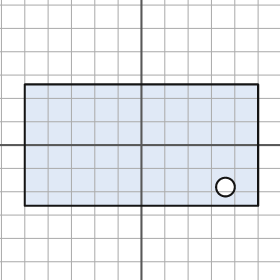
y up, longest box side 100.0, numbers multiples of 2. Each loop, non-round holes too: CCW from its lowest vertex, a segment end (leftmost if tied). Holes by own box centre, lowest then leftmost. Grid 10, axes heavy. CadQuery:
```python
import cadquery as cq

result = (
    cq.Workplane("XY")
    .moveTo(-50.0, -26.0)
    .lineTo(50.0, -26.0)
    .lineTo(50.0, 26.0)
    .lineTo(-50.0, 26.0)
    .close()
    .moveTo(36.0, -18.0)
    .circle(4.0)
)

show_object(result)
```